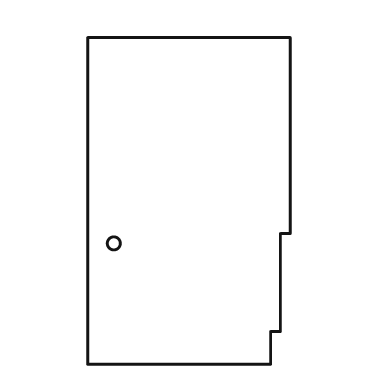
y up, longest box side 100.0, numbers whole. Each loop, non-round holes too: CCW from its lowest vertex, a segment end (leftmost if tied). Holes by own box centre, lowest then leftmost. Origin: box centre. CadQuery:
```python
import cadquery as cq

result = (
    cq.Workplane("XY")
    .moveTo(-31.0, -50.0)
    .lineTo(25.0, -50.0)
    .lineTo(25.0, -40.0)
    .lineTo(28.0, -40.0)
    .lineTo(28.0, -10.0)
    .lineTo(31.0, -10.0)
    .lineTo(31.0, 50.0)
    .lineTo(-31.0, 50.0)
    .close()
    .moveTo(-23.0, -13.0)
    .circle(2.0)
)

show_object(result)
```